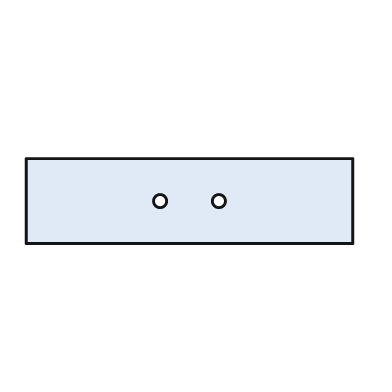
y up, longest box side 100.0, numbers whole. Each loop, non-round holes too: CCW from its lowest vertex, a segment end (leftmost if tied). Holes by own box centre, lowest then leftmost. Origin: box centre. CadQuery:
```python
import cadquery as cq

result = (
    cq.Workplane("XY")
    .moveTo(-50.0, -13.0)
    .lineTo(50.0, -13.0)
    .lineTo(50.0, 13.0)
    .lineTo(-50.0, 13.0)
    .close()
    .moveTo(-9.0, 0.0)
    .circle(2.0)
    .moveTo(9.0, 0.0)
    .circle(2.0)
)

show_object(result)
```